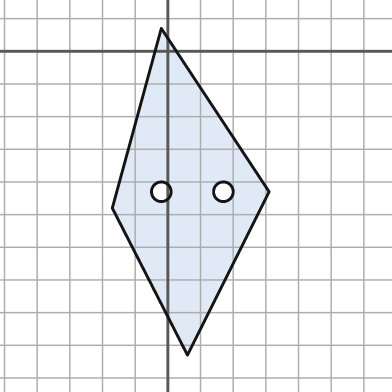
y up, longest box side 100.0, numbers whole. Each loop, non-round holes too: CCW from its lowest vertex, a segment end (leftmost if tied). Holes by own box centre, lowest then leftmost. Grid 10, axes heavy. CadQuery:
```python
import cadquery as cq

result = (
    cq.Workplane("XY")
    .moveTo(6.0, -93.0)
    .lineTo(31.0, -43.0)
    .lineTo(-2.0, 7.0)
    .lineTo(-17.0, -48.0)
    .close()
    .moveTo(-2.0, -43.0)
    .circle(3.0)
    .moveTo(17.0, -43.0)
    .circle(3.0)
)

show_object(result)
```